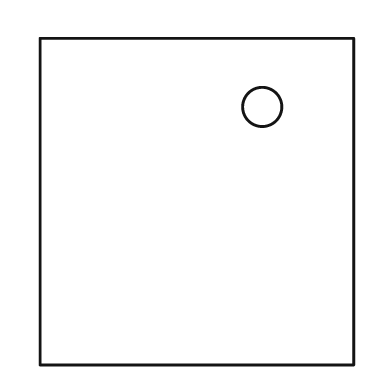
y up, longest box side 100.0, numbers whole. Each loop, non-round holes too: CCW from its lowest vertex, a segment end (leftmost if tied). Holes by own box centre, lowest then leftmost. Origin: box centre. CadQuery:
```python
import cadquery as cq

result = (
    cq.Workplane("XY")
    .moveTo(-48.0, -50.0)
    .lineTo(48.0, -50.0)
    .lineTo(48.0, 50.0)
    .lineTo(-48.0, 50.0)
    .close()
    .moveTo(20.0, 29.0)
    .circle(6.0)
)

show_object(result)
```